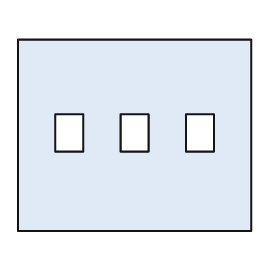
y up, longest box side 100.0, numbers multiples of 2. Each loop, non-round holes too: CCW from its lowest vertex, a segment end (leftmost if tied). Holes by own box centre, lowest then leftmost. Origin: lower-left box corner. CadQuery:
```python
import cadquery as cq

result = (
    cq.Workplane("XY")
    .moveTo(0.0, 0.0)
    .lineTo(100.0, 0.0)
    .lineTo(100.0, 82.0)
    .lineTo(0.0, 82.0)
    .close()
    .moveTo(16.0, 34.0)
    .lineTo(28.0, 34.0)
    .lineTo(28.0, 50.0)
    .lineTo(16.0, 50.0)
    .close()
    .moveTo(44.0, 34.0)
    .lineTo(56.0, 34.0)
    .lineTo(56.0, 50.0)
    .lineTo(44.0, 50.0)
    .close()
    .moveTo(72.0, 34.0)
    .lineTo(84.0, 34.0)
    .lineTo(84.0, 50.0)
    .lineTo(72.0, 50.0)
    .close()
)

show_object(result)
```